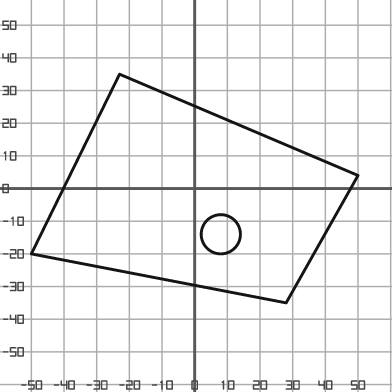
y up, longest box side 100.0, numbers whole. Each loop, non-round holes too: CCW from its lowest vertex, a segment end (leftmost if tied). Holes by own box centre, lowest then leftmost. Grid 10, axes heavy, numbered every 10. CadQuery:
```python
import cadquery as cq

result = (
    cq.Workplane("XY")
    .moveTo(28.0, -35.0)
    .lineTo(50.0, 4.0)
    .lineTo(-23.0, 35.0)
    .lineTo(-50.0, -20.0)
    .close()
    .moveTo(8.0, -14.0)
    .circle(6.0)
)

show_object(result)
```